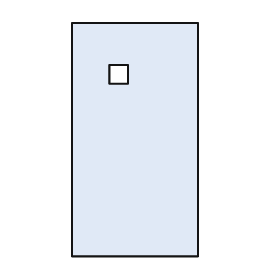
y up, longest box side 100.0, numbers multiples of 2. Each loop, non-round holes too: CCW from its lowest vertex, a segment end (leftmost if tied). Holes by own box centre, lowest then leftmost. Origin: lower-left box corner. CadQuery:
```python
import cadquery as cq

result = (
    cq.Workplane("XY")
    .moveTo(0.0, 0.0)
    .lineTo(54.0, 0.0)
    .lineTo(54.0, 100.0)
    .lineTo(0.0, 100.0)
    .close()
    .moveTo(16.0, 74.0)
    .lineTo(24.0, 74.0)
    .lineTo(24.0, 82.0)
    .lineTo(16.0, 82.0)
    .close()
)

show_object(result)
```